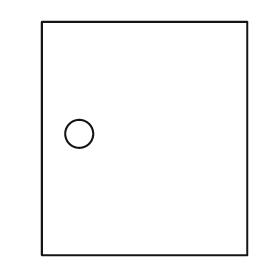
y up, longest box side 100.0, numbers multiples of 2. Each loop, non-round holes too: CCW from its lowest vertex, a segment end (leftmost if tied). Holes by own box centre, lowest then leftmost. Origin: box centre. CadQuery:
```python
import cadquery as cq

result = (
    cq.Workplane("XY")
    .moveTo(-44.0, -50.0)
    .lineTo(44.0, -50.0)
    .lineTo(44.0, 50.0)
    .lineTo(-44.0, 50.0)
    .close()
    .moveTo(-28.0, 2.0)
    .circle(6.0)
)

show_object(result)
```